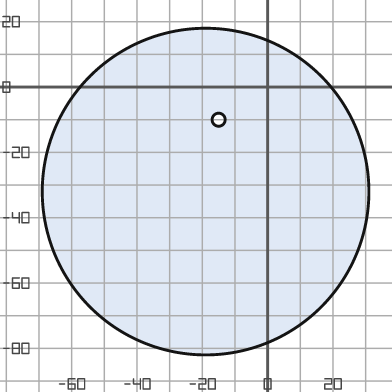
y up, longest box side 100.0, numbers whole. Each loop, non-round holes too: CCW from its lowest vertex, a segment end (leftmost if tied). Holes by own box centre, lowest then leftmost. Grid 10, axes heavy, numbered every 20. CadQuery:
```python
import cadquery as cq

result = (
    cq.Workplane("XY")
    .moveTo(-19.0, -32.0)
    .circle(50.0)
    .moveTo(-15.0, -10.0)
    .circle(2.0)
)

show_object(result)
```